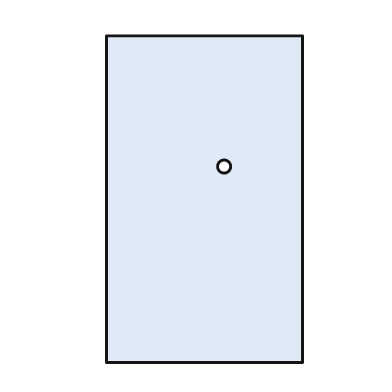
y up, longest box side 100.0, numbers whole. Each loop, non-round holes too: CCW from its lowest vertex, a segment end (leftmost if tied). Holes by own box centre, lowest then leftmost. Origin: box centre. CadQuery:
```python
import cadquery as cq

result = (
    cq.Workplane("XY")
    .moveTo(-30.0, -50.0)
    .lineTo(30.0, -50.0)
    .lineTo(30.0, 50.0)
    .lineTo(-30.0, 50.0)
    .close()
    .moveTo(6.0, 10.0)
    .circle(2.0)
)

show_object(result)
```